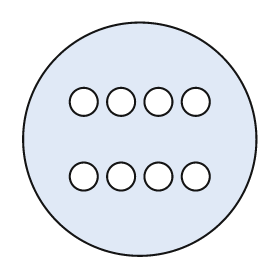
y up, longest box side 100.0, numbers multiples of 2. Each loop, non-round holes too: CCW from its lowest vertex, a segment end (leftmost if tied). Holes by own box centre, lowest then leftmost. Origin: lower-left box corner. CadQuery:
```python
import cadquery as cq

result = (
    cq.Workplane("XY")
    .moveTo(50.0, 50.0)
    .circle(50.0)
    .moveTo(26.0, 34.0)
    .circle(6.0)
    .moveTo(42.0, 34.0)
    .circle(6.0)
    .moveTo(58.0, 34.0)
    .circle(6.0)
    .moveTo(74.0, 34.0)
    .circle(6.0)
    .moveTo(26.0, 66.0)
    .circle(6.0)
    .moveTo(42.0, 66.0)
    .circle(6.0)
    .moveTo(58.0, 66.0)
    .circle(6.0)
    .moveTo(74.0, 66.0)
    .circle(6.0)
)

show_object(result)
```